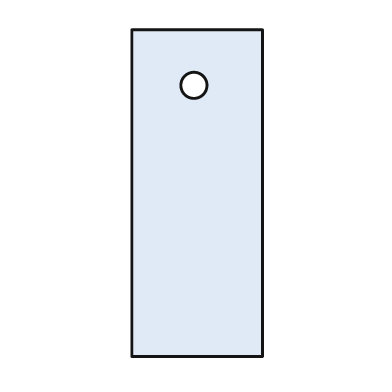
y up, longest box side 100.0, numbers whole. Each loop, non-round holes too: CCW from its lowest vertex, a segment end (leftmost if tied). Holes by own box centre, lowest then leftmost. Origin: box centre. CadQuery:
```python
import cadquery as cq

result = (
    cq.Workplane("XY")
    .moveTo(-20.0, -50.0)
    .lineTo(20.0, -50.0)
    .lineTo(20.0, 50.0)
    .lineTo(-20.0, 50.0)
    .close()
    .moveTo(-1.0, 33.0)
    .circle(4.0)
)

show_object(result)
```